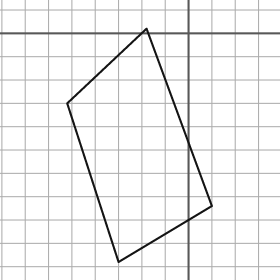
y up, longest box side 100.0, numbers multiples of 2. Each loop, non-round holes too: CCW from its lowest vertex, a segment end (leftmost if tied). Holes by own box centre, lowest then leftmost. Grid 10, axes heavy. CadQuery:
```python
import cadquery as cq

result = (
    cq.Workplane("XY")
    .moveTo(-30.0, -98.0)
    .lineTo(10.0, -74.0)
    .lineTo(-18.0, 2.0)
    .lineTo(-52.0, -30.0)
    .close()
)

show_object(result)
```